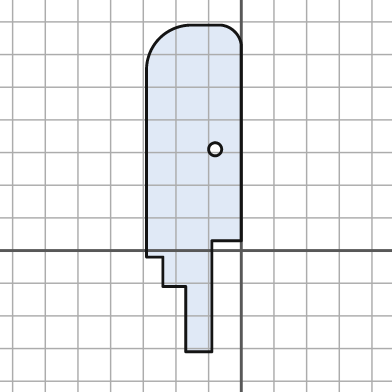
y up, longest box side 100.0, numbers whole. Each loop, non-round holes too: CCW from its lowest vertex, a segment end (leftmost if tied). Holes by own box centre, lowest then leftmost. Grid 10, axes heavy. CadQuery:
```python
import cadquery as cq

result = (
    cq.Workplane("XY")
    .moveTo(-17.0, -31.0)
    .lineTo(-9.0, -31.0)
    .lineTo(-9.0, 3.0)
    .lineTo(0.0, 3.0)
    .lineTo(0.0, 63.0)
    .threePointArc((-2.0, 67.0), (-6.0, 69.0))
    .lineTo(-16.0, 69.0)
    .threePointArc((-25.0, 65.0), (-29.0, 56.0))
    .lineTo(-29.0, -2.0)
    .lineTo(-24.0, -2.0)
    .lineTo(-24.0, -11.0)
    .lineTo(-17.0, -11.0)
    .close()
    .moveTo(-8.0, 31.0)
    .circle(2.0)
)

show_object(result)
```